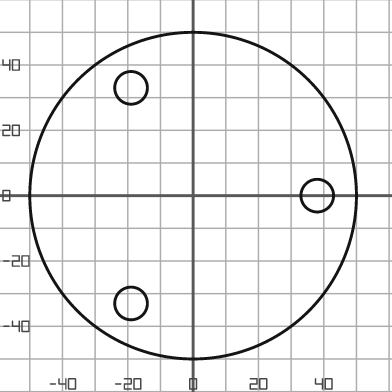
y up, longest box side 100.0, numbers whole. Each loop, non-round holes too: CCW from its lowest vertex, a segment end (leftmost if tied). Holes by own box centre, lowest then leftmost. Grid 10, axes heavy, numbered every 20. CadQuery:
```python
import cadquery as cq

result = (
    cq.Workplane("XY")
    .moveTo(0.0, 0.0)
    .circle(50.0)
    .moveTo(-19.0, -33.0)
    .circle(5.0)
    .moveTo(38.0, 0.0)
    .circle(5.0)
    .moveTo(-19.0, 33.0)
    .circle(5.0)
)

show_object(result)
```